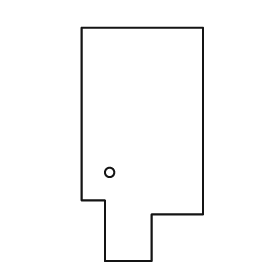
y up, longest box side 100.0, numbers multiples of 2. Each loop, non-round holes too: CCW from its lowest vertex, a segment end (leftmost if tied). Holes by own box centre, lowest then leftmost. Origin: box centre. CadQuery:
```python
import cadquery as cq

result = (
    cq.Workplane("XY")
    .moveTo(-16.0, -50.0)
    .lineTo(4.0, -50.0)
    .lineTo(4.0, -30.0)
    .lineTo(26.0, -30.0)
    .lineTo(26.0, 50.0)
    .lineTo(-26.0, 50.0)
    .lineTo(-26.0, -24.0)
    .lineTo(-16.0, -24.0)
    .close()
    .moveTo(-14.0, -12.0)
    .circle(2.0)
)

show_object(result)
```